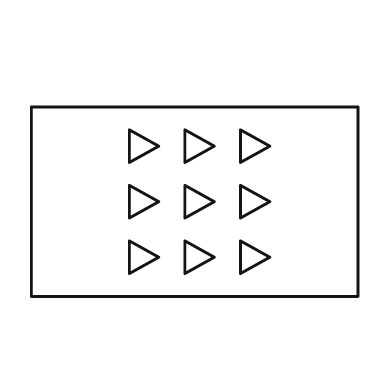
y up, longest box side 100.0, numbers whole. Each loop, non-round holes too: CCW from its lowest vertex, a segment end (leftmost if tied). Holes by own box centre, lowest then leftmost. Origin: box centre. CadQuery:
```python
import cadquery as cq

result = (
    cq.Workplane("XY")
    .moveTo(-50.0, -29.0)
    .lineTo(50.0, -29.0)
    .lineTo(50.0, 29.0)
    .lineTo(-50.0, 29.0)
    .close()
    .moveTo(-20.0, -22.0)
    .lineTo(-11.0, -17.0)
    .lineTo(-20.0, -12.0)
    .close()
    .moveTo(-3.0, -22.0)
    .lineTo(6.0, -17.0)
    .lineTo(-3.0, -12.0)
    .close()
    .moveTo(14.0, -22.0)
    .lineTo(23.0, -17.0)
    .lineTo(14.0, -12.0)
    .close()
    .moveTo(-20.0, -5.0)
    .lineTo(-11.0, 0.0)
    .lineTo(-20.0, 5.0)
    .close()
    .moveTo(-3.0, -5.0)
    .lineTo(6.0, 0.0)
    .lineTo(-3.0, 5.0)
    .close()
    .moveTo(14.0, -5.0)
    .lineTo(23.0, 0.0)
    .lineTo(14.0, 5.0)
    .close()
    .moveTo(-20.0, 12.0)
    .lineTo(-11.0, 17.0)
    .lineTo(-20.0, 22.0)
    .close()
    .moveTo(-3.0, 12.0)
    .lineTo(6.0, 17.0)
    .lineTo(-3.0, 22.0)
    .close()
    .moveTo(14.0, 12.0)
    .lineTo(23.0, 17.0)
    .lineTo(14.0, 22.0)
    .close()
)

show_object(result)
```